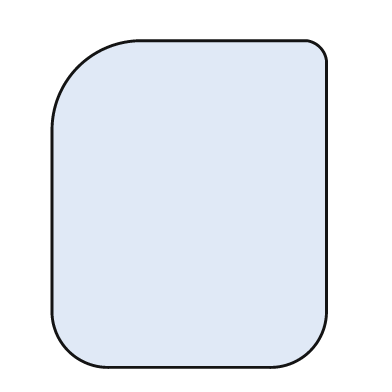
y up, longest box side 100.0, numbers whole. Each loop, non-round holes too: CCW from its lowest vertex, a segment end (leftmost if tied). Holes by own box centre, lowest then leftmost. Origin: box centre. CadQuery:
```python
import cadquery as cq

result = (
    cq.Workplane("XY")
    .moveTo(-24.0, -50.0)
    .lineTo(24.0, -50.0)
    .threePointArc((37.0, -45.0), (42.0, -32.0))
    .lineTo(42.0, 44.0)
    .threePointArc((40.0, 48.0), (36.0, 50.0))
    .lineTo(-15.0, 50.0)
    .threePointArc((-34.0, 42.0), (-42.0, 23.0))
    .lineTo(-42.0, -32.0)
    .threePointArc((-37.0, -45.0), (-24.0, -50.0))
    .close()
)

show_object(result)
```